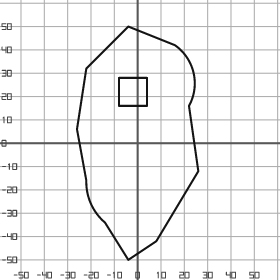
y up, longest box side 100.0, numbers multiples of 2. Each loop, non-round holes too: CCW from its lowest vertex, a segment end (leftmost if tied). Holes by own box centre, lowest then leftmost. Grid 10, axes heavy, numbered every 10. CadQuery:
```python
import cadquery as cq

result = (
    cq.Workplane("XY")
    .moveTo(-4.0, -50.0)
    .lineTo(8.0, -42.0)
    .lineTo(26.0, -12.0)
    .lineTo(22.0, 16.0)
    .threePointArc((24.0, 30.0), (16.0, 42.0))
    .lineTo(-4.0, 50.0)
    .lineTo(-22.0, 32.0)
    .lineTo(-26.0, 6.0)
    .lineTo(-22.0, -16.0)
    .threePointArc((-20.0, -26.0), (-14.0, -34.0))
    .close()
    .moveTo(-8.0, 16.0)
    .lineTo(4.0, 16.0)
    .lineTo(4.0, 28.0)
    .lineTo(-8.0, 28.0)
    .close()
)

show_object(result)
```